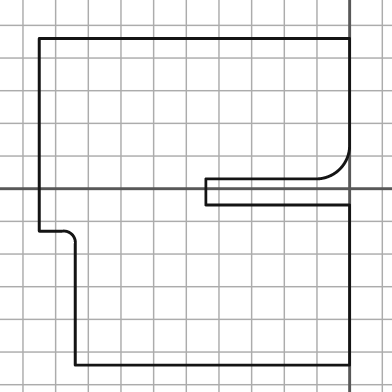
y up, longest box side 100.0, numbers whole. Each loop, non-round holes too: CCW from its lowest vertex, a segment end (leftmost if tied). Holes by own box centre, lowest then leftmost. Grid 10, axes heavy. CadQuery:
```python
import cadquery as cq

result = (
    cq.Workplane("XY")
    .moveTo(-84.0, -54.0)
    .lineTo(0.0, -54.0)
    .lineTo(0.0, -5.0)
    .lineTo(-44.0, -5.0)
    .lineTo(-44.0, 3.0)
    .lineTo(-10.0, 3.0)
    .threePointArc((-3.0, 6.0), (0.0, 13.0))
    .lineTo(0.0, 46.0)
    .lineTo(-95.0, 46.0)
    .lineTo(-95.0, -13.0)
    .lineTo(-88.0, -13.0)
    .threePointArc((-85.0, -14.0), (-84.0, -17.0))
    .close()
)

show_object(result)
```